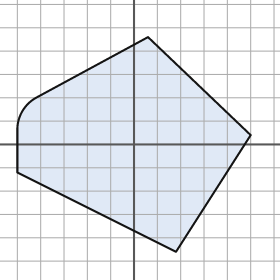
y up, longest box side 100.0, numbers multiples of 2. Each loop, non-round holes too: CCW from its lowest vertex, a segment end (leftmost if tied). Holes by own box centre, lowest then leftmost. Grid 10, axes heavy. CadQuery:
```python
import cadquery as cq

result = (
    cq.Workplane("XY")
    .moveTo(18.0, -46.0)
    .lineTo(50.0, 4.0)
    .lineTo(6.0, 46.0)
    .lineTo(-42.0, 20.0)
    .threePointArc((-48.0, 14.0), (-50.0, 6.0))
    .lineTo(-50.0, -12.0)
    .close()
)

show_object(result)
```